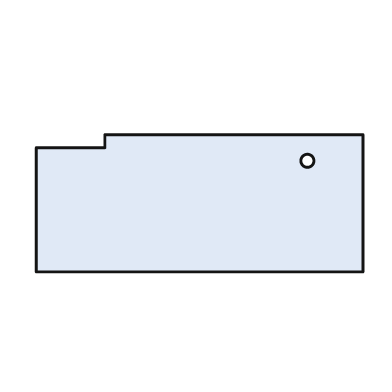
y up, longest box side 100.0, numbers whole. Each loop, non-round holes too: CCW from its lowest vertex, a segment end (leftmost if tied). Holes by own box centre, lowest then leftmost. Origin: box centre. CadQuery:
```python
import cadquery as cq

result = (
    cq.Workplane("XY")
    .moveTo(-50.0, -21.0)
    .lineTo(50.0, -21.0)
    .lineTo(50.0, 21.0)
    .lineTo(-29.0, 21.0)
    .lineTo(-29.0, 17.0)
    .lineTo(-50.0, 17.0)
    .close()
    .moveTo(33.0, 13.0)
    .circle(2.0)
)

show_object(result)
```